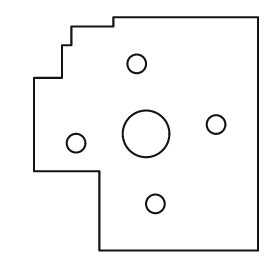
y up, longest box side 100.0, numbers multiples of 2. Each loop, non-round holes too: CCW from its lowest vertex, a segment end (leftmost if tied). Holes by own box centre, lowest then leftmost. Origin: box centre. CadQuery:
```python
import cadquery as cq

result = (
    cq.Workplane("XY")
    .moveTo(-20.0, -50.0)
    .lineTo(48.0, -50.0)
    .lineTo(48.0, 50.0)
    .lineTo(-14.0, 50.0)
    .lineTo(-14.0, 46.0)
    .lineTo(-32.0, 46.0)
    .lineTo(-32.0, 38.0)
    .lineTo(-36.0, 38.0)
    .lineTo(-36.0, 24.0)
    .lineTo(-48.0, 24.0)
    .lineTo(-48.0, -16.0)
    .lineTo(-20.0, -16.0)
    .close()
    .moveTo(4.0, -30.0)
    .circle(4.0)
    .moveTo(-30.0, -4.0)
    .circle(4.0)
    .moveTo(0.0, 0.0)
    .circle(10.0)
    .moveTo(30.0, 4.0)
    .circle(4.0)
    .moveTo(-4.0, 30.0)
    .circle(4.0)
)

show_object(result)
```